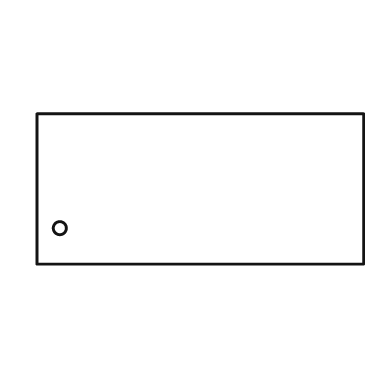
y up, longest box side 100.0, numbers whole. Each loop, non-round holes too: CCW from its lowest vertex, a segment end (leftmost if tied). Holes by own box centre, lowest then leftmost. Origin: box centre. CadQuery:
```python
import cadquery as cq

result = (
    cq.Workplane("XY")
    .moveTo(-50.0, -23.0)
    .lineTo(50.0, -23.0)
    .lineTo(50.0, 23.0)
    .lineTo(-50.0, 23.0)
    .close()
    .moveTo(-43.0, -12.0)
    .circle(2.0)
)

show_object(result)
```